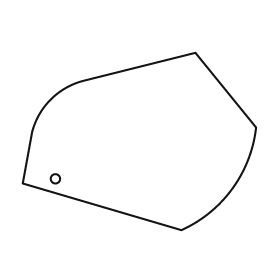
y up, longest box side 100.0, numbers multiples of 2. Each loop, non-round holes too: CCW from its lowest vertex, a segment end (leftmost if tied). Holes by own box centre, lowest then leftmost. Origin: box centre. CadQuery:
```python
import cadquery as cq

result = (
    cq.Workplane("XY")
    .moveTo(18.0, -38.0)
    .threePointArc((40.0, -20.0), (50.0, 6.0))
    .lineTo(24.0, 38.0)
    .lineTo(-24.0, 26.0)
    .threePointArc((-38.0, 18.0), (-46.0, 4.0))
    .lineTo(-50.0, -18.0)
    .close()
    .moveTo(-36.0, -16.0)
    .circle(2.0)
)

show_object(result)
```